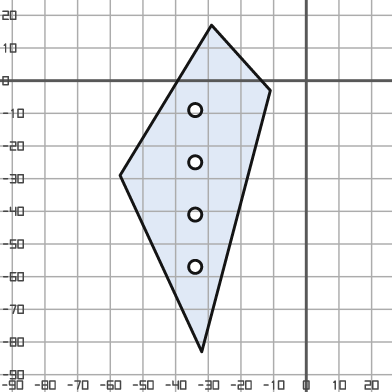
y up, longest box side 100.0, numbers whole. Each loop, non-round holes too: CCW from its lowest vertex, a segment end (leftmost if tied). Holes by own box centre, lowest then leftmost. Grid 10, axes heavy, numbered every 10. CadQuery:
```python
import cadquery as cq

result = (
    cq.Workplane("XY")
    .moveTo(-32.0, -83.0)
    .lineTo(-11.0, -3.0)
    .lineTo(-29.0, 17.0)
    .lineTo(-57.0, -29.0)
    .close()
    .moveTo(-34.0, -57.0)
    .circle(2.0)
    .moveTo(-34.0, -41.0)
    .circle(2.0)
    .moveTo(-34.0, -25.0)
    .circle(2.0)
    .moveTo(-34.0, -9.0)
    .circle(2.0)
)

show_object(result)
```